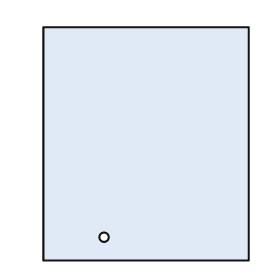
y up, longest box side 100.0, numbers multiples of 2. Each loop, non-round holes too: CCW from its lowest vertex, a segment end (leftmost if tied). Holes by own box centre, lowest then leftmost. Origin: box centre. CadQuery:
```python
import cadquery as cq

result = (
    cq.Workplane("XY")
    .moveTo(-44.0, -50.0)
    .lineTo(44.0, -50.0)
    .lineTo(44.0, 50.0)
    .lineTo(-44.0, 50.0)
    .close()
    .moveTo(-18.0, -40.0)
    .circle(2.0)
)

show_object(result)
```